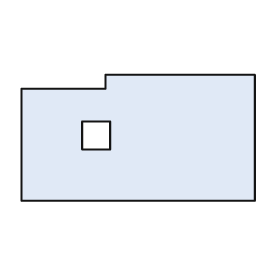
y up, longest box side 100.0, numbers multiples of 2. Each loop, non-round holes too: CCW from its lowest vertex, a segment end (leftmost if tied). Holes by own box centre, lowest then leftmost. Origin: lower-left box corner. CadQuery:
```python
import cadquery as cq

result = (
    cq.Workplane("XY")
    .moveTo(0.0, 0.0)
    .lineTo(100.0, 0.0)
    .lineTo(100.0, 54.0)
    .lineTo(36.0, 54.0)
    .lineTo(36.0, 48.0)
    .lineTo(0.0, 48.0)
    .close()
    .moveTo(26.0, 22.0)
    .lineTo(38.0, 22.0)
    .lineTo(38.0, 34.0)
    .lineTo(26.0, 34.0)
    .close()
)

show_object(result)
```